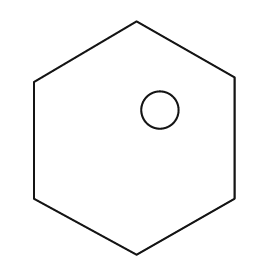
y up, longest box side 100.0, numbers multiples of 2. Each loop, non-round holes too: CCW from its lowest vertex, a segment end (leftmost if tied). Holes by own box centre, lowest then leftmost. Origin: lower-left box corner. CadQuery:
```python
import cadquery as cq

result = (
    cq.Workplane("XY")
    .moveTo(44.0, 0.0)
    .lineTo(86.0, 24.0)
    .lineTo(86.0, 76.0)
    .lineTo(44.0, 100.0)
    .lineTo(0.0, 74.0)
    .lineTo(0.0, 24.0)
    .close()
    .moveTo(54.0, 62.0)
    .circle(8.0)
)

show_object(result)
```